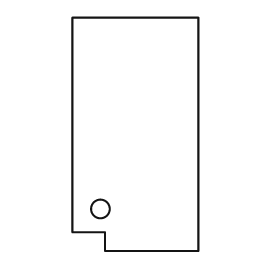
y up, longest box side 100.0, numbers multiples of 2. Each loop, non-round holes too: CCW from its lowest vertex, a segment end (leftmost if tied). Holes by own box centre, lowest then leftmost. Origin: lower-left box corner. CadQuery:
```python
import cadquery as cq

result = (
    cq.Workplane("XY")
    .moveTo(14.0, 0.0)
    .lineTo(54.0, 0.0)
    .lineTo(54.0, 100.0)
    .lineTo(0.0, 100.0)
    .lineTo(0.0, 8.0)
    .lineTo(14.0, 8.0)
    .close()
    .moveTo(12.0, 18.0)
    .circle(4.0)
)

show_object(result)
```